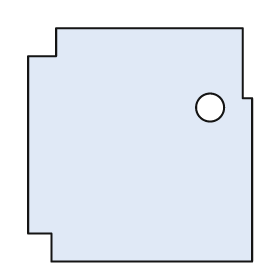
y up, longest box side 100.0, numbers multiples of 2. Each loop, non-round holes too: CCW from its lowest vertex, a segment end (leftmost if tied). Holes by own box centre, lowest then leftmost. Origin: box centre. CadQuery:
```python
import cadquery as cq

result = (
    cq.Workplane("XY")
    .moveTo(-38.0, -50.0)
    .lineTo(48.0, -50.0)
    .lineTo(48.0, 20.0)
    .lineTo(44.0, 20.0)
    .lineTo(44.0, 50.0)
    .lineTo(-36.0, 50.0)
    .lineTo(-36.0, 38.0)
    .lineTo(-48.0, 38.0)
    .lineTo(-48.0, -38.0)
    .lineTo(-38.0, -38.0)
    .close()
    .moveTo(30.0, 16.0)
    .circle(6.0)
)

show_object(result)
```